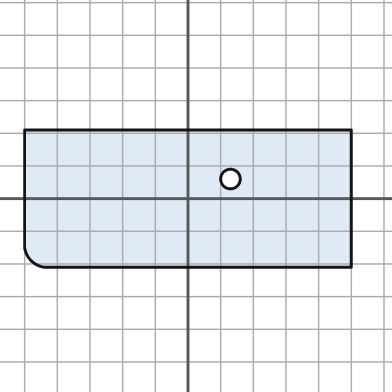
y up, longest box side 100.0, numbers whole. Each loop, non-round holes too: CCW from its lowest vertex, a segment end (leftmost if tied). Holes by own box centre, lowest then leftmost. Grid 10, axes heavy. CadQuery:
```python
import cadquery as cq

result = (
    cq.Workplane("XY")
    .moveTo(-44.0, -21.0)
    .lineTo(50.0, -21.0)
    .lineTo(50.0, 21.0)
    .lineTo(-50.0, 21.0)
    .lineTo(-50.0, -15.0)
    .threePointArc((-48.0, -19.0), (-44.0, -21.0))
    .close()
    .moveTo(13.0, 6.0)
    .circle(3.0)
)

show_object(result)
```